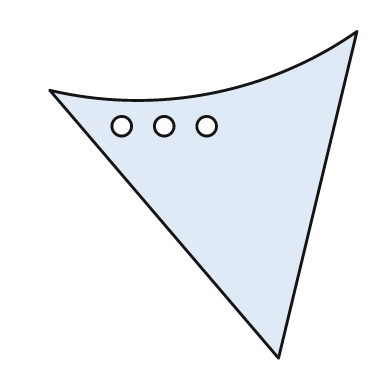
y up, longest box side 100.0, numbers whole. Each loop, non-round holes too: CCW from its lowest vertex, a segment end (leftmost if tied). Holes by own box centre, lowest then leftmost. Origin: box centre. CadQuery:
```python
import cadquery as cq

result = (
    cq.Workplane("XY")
    .moveTo(23.0, -50.0)
    .lineTo(47.0, 50.0)
    .threePointArc((2.0, 31.0), (-47.0, 32.0))
    .close()
    .moveTo(-25.0, 21.0)
    .circle(3.0)
    .moveTo(-12.0, 21.0)
    .circle(3.0)
    .moveTo(1.0, 21.0)
    .circle(3.0)
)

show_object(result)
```